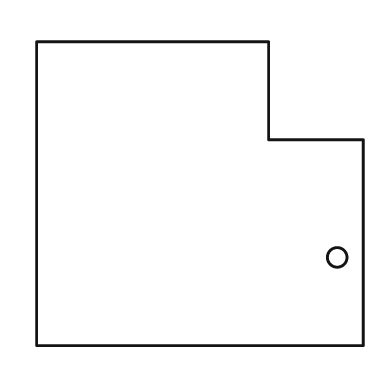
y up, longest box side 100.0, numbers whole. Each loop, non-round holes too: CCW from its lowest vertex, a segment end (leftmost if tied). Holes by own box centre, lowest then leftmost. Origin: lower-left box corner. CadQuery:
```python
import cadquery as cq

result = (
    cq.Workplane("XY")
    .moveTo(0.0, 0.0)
    .lineTo(100.0, 0.0)
    .lineTo(100.0, 63.0)
    .lineTo(71.0, 63.0)
    .lineTo(71.0, 93.0)
    .lineTo(0.0, 93.0)
    .close()
    .moveTo(92.0, 27.0)
    .circle(3.0)
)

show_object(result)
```